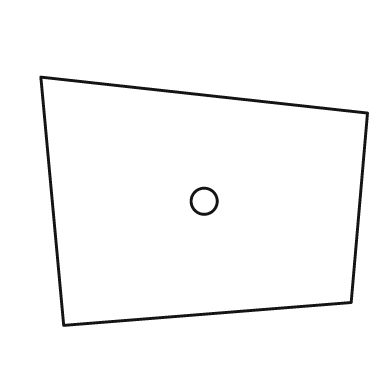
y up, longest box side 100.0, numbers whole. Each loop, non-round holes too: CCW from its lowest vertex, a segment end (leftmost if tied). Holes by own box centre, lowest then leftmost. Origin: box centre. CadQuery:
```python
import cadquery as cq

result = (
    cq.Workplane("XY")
    .moveTo(-43.0, -38.0)
    .lineTo(45.0, -31.0)
    .lineTo(50.0, 27.0)
    .lineTo(-50.0, 38.0)
    .close()
    .moveTo(0.0, 0.0)
    .circle(4.0)
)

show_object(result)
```